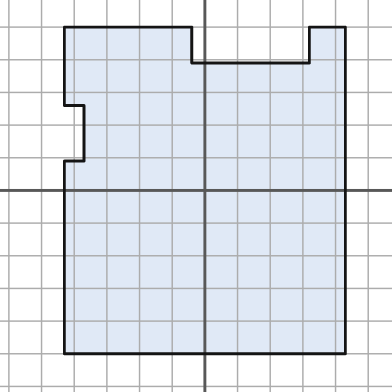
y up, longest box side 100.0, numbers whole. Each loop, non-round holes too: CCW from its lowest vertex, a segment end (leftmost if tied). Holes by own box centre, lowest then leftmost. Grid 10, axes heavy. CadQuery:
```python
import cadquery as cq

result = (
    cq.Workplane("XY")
    .moveTo(-43.0, -50.0)
    .lineTo(43.0, -50.0)
    .lineTo(43.0, 50.0)
    .lineTo(32.0, 50.0)
    .lineTo(32.0, 39.0)
    .lineTo(-4.0, 39.0)
    .lineTo(-4.0, 50.0)
    .lineTo(-43.0, 50.0)
    .lineTo(-43.0, 26.0)
    .lineTo(-37.0, 26.0)
    .lineTo(-37.0, 9.0)
    .lineTo(-43.0, 9.0)
    .close()
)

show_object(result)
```